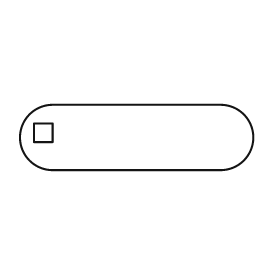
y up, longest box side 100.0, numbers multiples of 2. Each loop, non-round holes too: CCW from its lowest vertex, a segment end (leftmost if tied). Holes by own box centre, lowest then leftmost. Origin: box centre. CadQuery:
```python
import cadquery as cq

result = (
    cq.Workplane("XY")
    .moveTo(-36.0, -14.0)
    .lineTo(36.0, -14.0)
    .threePointArc((50.0, 0.0), (36.0, 14.0))
    .lineTo(-36.0, 14.0)
    .threePointArc((-50.0, 0.0), (-36.0, -14.0))
    .close()
    .moveTo(-44.0, -2.0)
    .lineTo(-36.0, -2.0)
    .lineTo(-36.0, 6.0)
    .lineTo(-44.0, 6.0)
    .close()
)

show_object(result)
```